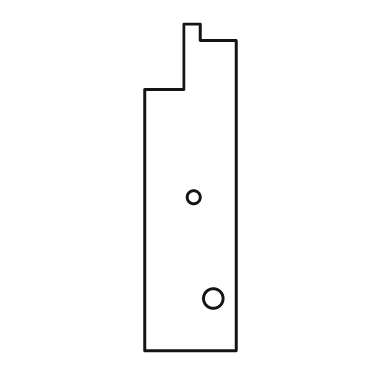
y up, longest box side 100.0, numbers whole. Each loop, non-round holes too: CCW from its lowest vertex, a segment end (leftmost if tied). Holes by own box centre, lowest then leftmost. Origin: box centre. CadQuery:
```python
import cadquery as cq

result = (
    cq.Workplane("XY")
    .moveTo(-14.0, -50.0)
    .lineTo(14.0, -50.0)
    .lineTo(14.0, 45.0)
    .lineTo(3.0, 45.0)
    .lineTo(3.0, 50.0)
    .lineTo(-2.0, 50.0)
    .lineTo(-2.0, 30.0)
    .lineTo(-14.0, 30.0)
    .close()
    .moveTo(7.0, -34.0)
    .circle(3.0)
    .moveTo(1.0, -3.0)
    .circle(2.0)
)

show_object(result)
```